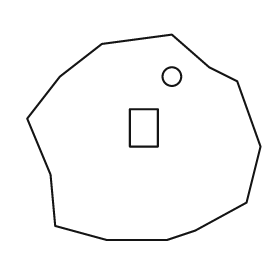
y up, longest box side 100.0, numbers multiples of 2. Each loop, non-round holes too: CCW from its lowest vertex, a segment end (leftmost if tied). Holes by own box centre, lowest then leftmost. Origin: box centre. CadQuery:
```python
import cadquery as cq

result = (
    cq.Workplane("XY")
    .moveTo(-16.0, -44.0)
    .lineTo(10.0, -44.0)
    .lineTo(22.0, -40.0)
    .lineTo(44.0, -28.0)
    .lineTo(50.0, -4.0)
    .lineTo(40.0, 24.0)
    .lineTo(28.0, 30.0)
    .lineTo(12.0, 44.0)
    .lineTo(-18.0, 40.0)
    .lineTo(-36.0, 26.0)
    .lineTo(-50.0, 8.0)
    .lineTo(-40.0, -16.0)
    .lineTo(-38.0, -38.0)
    .close()
    .moveTo(-6.0, -4.0)
    .lineTo(6.0, -4.0)
    .lineTo(6.0, 12.0)
    .lineTo(-6.0, 12.0)
    .close()
    .moveTo(12.0, 26.0)
    .circle(4.0)
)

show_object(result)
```